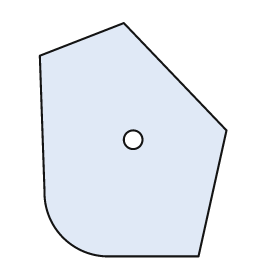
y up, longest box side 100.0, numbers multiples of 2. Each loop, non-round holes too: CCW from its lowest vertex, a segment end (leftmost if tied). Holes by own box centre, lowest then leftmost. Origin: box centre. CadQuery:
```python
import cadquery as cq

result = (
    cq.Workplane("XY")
    .moveTo(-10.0, -50.0)
    .lineTo(28.0, -50.0)
    .lineTo(40.0, 4.0)
    .lineTo(-4.0, 50.0)
    .lineTo(-40.0, 36.0)
    .lineTo(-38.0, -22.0)
    .threePointArc((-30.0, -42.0), (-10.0, -50.0))
    .close()
    .moveTo(0.0, 0.0)
    .circle(4.0)
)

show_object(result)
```